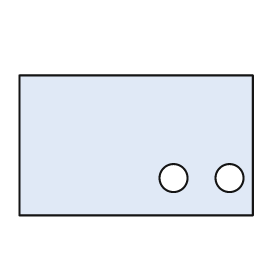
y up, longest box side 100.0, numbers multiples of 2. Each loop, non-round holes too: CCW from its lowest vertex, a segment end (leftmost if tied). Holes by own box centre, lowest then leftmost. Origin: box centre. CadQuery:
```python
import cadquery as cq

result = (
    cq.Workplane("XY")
    .moveTo(-50.0, -30.0)
    .lineTo(50.0, -30.0)
    .lineTo(50.0, 30.0)
    .lineTo(-50.0, 30.0)
    .close()
    .moveTo(16.0, -14.0)
    .circle(6.0)
    .moveTo(40.0, -14.0)
    .circle(6.0)
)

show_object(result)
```